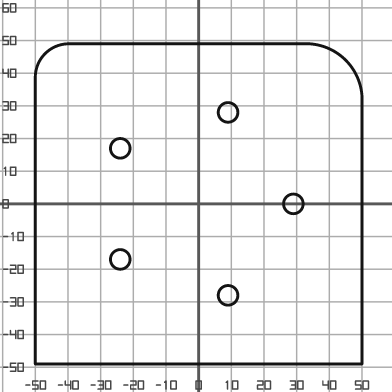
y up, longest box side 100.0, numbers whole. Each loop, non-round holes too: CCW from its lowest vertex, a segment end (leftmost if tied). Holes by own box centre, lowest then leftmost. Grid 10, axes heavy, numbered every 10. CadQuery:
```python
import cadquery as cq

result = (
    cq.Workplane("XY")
    .moveTo(-50.0, -49.0)
    .lineTo(50.0, -49.0)
    .lineTo(50.0, 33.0)
    .threePointArc((45.0, 44.0), (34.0, 49.0))
    .lineTo(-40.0, 49.0)
    .threePointArc((-47.0, 46.0), (-50.0, 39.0))
    .close()
    .moveTo(9.0, -28.0)
    .circle(3.0)
    .moveTo(-24.0, -17.0)
    .circle(3.0)
    .moveTo(29.0, 0.0)
    .circle(3.0)
    .moveTo(-24.0, 17.0)
    .circle(3.0)
    .moveTo(9.0, 28.0)
    .circle(3.0)
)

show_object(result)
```